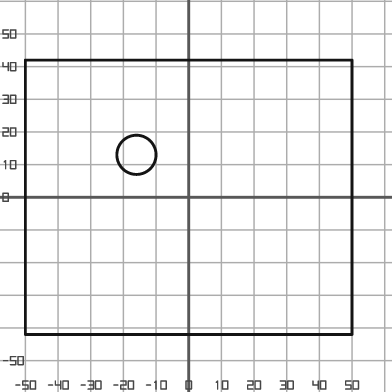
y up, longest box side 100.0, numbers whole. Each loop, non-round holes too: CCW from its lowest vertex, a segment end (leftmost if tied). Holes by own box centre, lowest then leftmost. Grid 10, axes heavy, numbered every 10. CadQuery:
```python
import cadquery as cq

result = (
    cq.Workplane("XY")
    .moveTo(-50.0, -42.0)
    .lineTo(50.0, -42.0)
    .lineTo(50.0, 42.0)
    .lineTo(-50.0, 42.0)
    .close()
    .moveTo(-16.0, 13.0)
    .circle(6.0)
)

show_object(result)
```